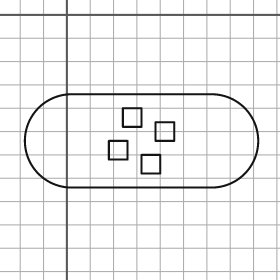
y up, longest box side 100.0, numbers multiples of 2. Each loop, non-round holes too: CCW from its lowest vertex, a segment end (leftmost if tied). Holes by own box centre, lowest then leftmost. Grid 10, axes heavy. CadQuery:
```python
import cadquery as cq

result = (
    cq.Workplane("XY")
    .moveTo(2.0, -74.0)
    .lineTo(62.0, -74.0)
    .threePointArc((82.0, -54.0), (62.0, -34.0))
    .lineTo(2.0, -34.0)
    .threePointArc((-18.0, -54.0), (2.0, -74.0))
    .close()
    .moveTo(32.0, -68.0)
    .lineTo(40.0, -68.0)
    .lineTo(40.0, -60.0)
    .lineTo(32.0, -60.0)
    .close()
    .moveTo(18.0, -62.0)
    .lineTo(26.0, -62.0)
    .lineTo(26.0, -54.0)
    .lineTo(18.0, -54.0)
    .close()
    .moveTo(38.0, -54.0)
    .lineTo(46.0, -54.0)
    .lineTo(46.0, -46.0)
    .lineTo(38.0, -46.0)
    .close()
    .moveTo(24.0, -48.0)
    .lineTo(32.0, -48.0)
    .lineTo(32.0, -40.0)
    .lineTo(24.0, -40.0)
    .close()
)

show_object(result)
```